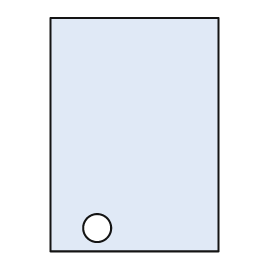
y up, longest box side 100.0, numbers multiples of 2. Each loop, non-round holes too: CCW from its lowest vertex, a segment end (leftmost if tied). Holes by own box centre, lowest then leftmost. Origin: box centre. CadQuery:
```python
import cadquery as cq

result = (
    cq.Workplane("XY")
    .moveTo(-36.0, -50.0)
    .lineTo(36.0, -50.0)
    .lineTo(36.0, 50.0)
    .lineTo(-36.0, 50.0)
    .close()
    .moveTo(-16.0, -40.0)
    .circle(6.0)
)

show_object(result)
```